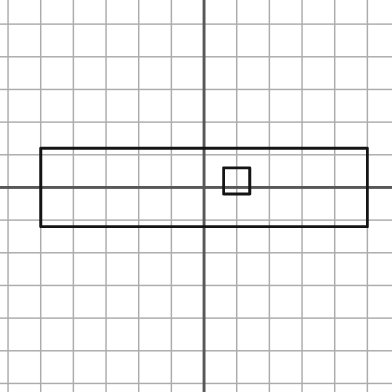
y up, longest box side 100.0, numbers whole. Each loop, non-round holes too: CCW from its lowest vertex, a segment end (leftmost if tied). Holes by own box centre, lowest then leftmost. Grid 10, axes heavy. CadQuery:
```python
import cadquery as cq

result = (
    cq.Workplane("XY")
    .moveTo(-50.0, -12.0)
    .lineTo(50.0, -12.0)
    .lineTo(50.0, 12.0)
    .lineTo(-50.0, 12.0)
    .close()
    .moveTo(6.0, -2.0)
    .lineTo(14.0, -2.0)
    .lineTo(14.0, 6.0)
    .lineTo(6.0, 6.0)
    .close()
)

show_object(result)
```